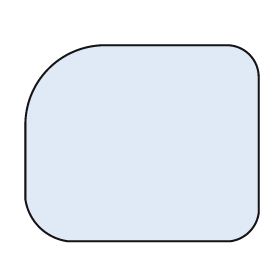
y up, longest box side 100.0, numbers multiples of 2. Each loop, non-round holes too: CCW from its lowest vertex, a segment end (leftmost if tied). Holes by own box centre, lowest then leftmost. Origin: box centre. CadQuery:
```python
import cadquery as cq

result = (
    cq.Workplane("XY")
    .moveTo(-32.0, -42.0)
    .lineTo(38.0, -42.0)
    .threePointArc((46.0, -38.0), (50.0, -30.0))
    .lineTo(50.0, 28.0)
    .threePointArc((46.0, 38.0), (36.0, 42.0))
    .lineTo(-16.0, 42.0)
    .threePointArc((-40.0, 32.0), (-50.0, 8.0))
    .lineTo(-50.0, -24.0)
    .threePointArc((-44.0, -36.0), (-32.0, -42.0))
    .close()
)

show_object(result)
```